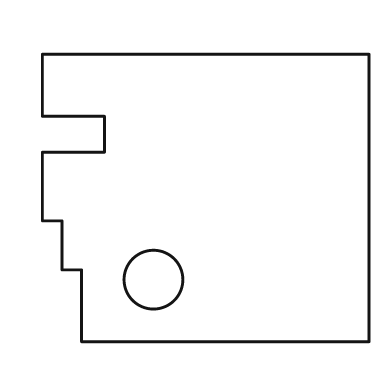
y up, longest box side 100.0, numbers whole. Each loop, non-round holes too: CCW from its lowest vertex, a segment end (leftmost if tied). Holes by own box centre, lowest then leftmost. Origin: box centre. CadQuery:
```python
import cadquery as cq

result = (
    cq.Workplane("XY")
    .moveTo(-38.0, -44.0)
    .lineTo(50.0, -44.0)
    .lineTo(50.0, 44.0)
    .lineTo(-50.0, 44.0)
    .lineTo(-50.0, 25.0)
    .lineTo(-31.0, 25.0)
    .lineTo(-31.0, 14.0)
    .lineTo(-50.0, 14.0)
    .lineTo(-50.0, -7.0)
    .lineTo(-44.0, -7.0)
    .lineTo(-44.0, -22.0)
    .lineTo(-38.0, -22.0)
    .close()
    .moveTo(-16.0, -25.0)
    .circle(9.0)
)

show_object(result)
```